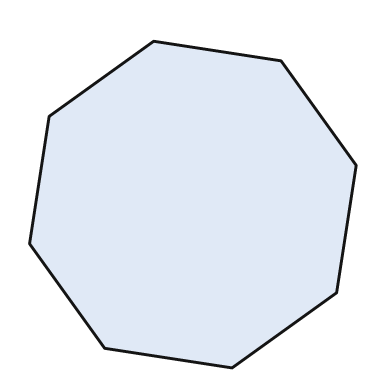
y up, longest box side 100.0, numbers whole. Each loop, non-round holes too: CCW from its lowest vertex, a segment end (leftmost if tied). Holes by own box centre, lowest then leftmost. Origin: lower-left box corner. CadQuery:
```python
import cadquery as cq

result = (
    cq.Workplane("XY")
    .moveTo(62.0, 0.0)
    .lineTo(94.0, 23.0)
    .lineTo(100.0, 62.0)
    .lineTo(77.0, 94.0)
    .lineTo(38.0, 100.0)
    .lineTo(6.0, 77.0)
    .lineTo(0.0, 38.0)
    .lineTo(23.0, 6.0)
    .close()
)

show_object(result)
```